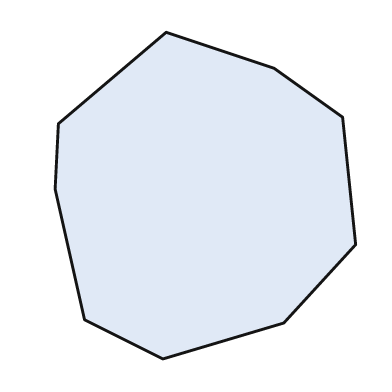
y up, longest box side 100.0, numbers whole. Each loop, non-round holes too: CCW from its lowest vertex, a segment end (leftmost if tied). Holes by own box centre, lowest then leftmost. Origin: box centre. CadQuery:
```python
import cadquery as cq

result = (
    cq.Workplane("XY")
    .moveTo(-13.0, -50.0)
    .lineTo(24.0, -39.0)
    .lineTo(46.0, -15.0)
    .lineTo(42.0, 24.0)
    .lineTo(21.0, 39.0)
    .lineTo(-12.0, 50.0)
    .lineTo(-45.0, 22.0)
    .lineTo(-46.0, 2.0)
    .lineTo(-37.0, -38.0)
    .close()
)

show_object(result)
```